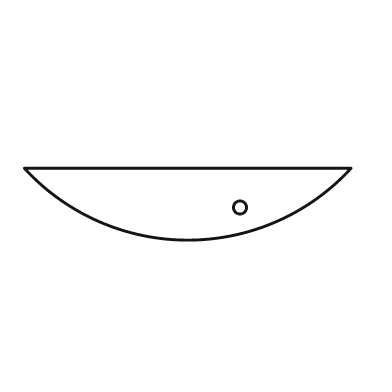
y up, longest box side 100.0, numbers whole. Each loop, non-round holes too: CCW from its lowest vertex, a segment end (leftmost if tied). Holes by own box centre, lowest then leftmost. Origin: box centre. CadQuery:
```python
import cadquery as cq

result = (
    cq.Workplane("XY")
    .moveTo(-50.0, 11.0)
    .threePointArc((0.0, -11.0), (50.0, 11.0))
    .close()
    .moveTo(16.0, -1.0)
    .circle(2.0)
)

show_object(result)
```